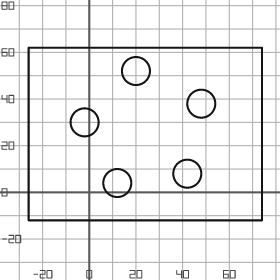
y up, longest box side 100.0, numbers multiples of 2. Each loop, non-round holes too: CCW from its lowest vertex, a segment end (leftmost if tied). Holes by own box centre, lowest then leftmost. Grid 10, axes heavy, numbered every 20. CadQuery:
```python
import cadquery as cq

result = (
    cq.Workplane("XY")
    .moveTo(-26.0, -12.0)
    .lineTo(74.0, -12.0)
    .lineTo(74.0, 62.0)
    .lineTo(-26.0, 62.0)
    .close()
    .moveTo(12.0, 4.0)
    .circle(6.0)
    .moveTo(42.0, 8.0)
    .circle(6.0)
    .moveTo(-2.0, 30.0)
    .circle(6.0)
    .moveTo(48.0, 38.0)
    .circle(6.0)
    .moveTo(20.0, 52.0)
    .circle(6.0)
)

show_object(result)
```